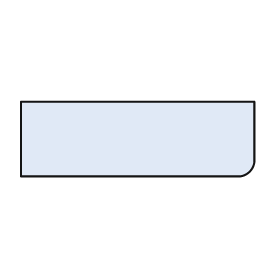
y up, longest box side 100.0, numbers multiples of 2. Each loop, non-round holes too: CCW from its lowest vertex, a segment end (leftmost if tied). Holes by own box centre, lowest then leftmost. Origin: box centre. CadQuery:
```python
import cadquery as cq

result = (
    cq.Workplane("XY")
    .moveTo(-50.0, -16.0)
    .lineTo(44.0, -16.0)
    .threePointArc((48.0, -14.0), (50.0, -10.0))
    .lineTo(50.0, 16.0)
    .lineTo(-50.0, 16.0)
    .close()
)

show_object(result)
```